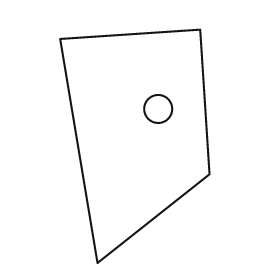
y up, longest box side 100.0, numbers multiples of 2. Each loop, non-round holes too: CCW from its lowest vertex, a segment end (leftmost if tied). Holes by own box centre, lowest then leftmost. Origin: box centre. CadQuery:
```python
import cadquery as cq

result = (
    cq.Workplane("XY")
    .moveTo(-16.0, -50.0)
    .lineTo(32.0, -12.0)
    .lineTo(28.0, 50.0)
    .lineTo(-32.0, 46.0)
    .close()
    .moveTo(10.0, 16.0)
    .circle(6.0)
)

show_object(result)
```